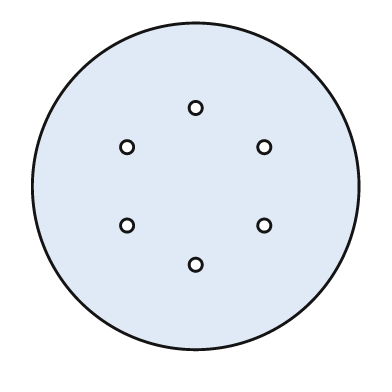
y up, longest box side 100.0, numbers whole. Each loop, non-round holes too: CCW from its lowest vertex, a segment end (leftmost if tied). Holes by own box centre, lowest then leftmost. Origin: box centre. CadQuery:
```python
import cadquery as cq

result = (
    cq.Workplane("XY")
    .moveTo(0.0, 0.0)
    .circle(50.0)
    .moveTo(0.0, -24.0)
    .circle(2.0)
    .moveTo(-21.0, -12.0)
    .circle(2.0)
    .moveTo(21.0, -12.0)
    .circle(2.0)
    .moveTo(-21.0, 12.0)
    .circle(2.0)
    .moveTo(21.0, 12.0)
    .circle(2.0)
    .moveTo(0.0, 24.0)
    .circle(2.0)
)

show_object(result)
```